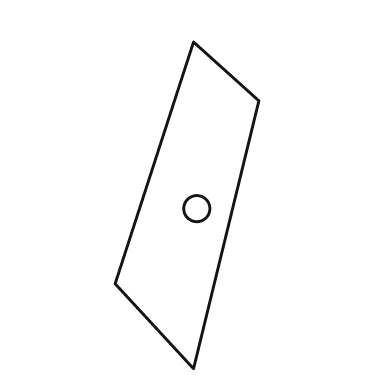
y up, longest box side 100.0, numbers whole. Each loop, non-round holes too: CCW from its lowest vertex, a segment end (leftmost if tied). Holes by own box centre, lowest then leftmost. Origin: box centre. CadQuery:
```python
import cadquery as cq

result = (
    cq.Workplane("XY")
    .moveTo(2.0, -50.0)
    .lineTo(22.0, 32.0)
    .lineTo(2.0, 50.0)
    .lineTo(-22.0, -24.0)
    .close()
    .moveTo(3.0, -1.0)
    .circle(4.0)
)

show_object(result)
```